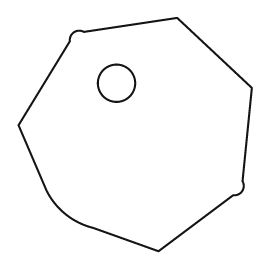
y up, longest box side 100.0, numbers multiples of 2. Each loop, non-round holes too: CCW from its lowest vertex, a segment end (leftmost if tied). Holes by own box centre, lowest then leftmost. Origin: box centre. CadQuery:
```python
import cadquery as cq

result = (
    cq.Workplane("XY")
    .moveTo(10.0, -50.0)
    .lineTo(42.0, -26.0)
    .threePointArc((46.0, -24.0), (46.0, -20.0))
    .lineTo(50.0, 20.0)
    .lineTo(18.0, 50.0)
    .lineTo(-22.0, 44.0)
    .threePointArc((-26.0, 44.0), (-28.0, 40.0))
    .lineTo(-50.0, 4.0)
    .lineTo(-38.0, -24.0)
    .threePointArc((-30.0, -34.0), (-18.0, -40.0))
    .close()
    .moveTo(-8.0, 22.0)
    .circle(8.0)
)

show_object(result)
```